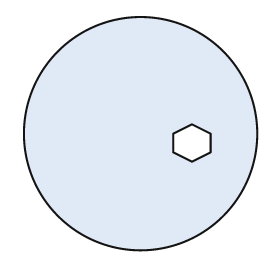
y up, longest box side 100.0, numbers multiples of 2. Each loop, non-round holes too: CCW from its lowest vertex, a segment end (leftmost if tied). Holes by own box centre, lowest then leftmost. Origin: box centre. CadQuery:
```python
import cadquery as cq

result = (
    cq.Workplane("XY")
    .moveTo(0.0, 0.0)
    .circle(50.0)
    .moveTo(22.0, -12.0)
    .lineTo(30.0, -8.0)
    .lineTo(30.0, 0.0)
    .lineTo(22.0, 4.0)
    .lineTo(14.0, 0.0)
    .lineTo(14.0, -8.0)
    .close()
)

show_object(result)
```